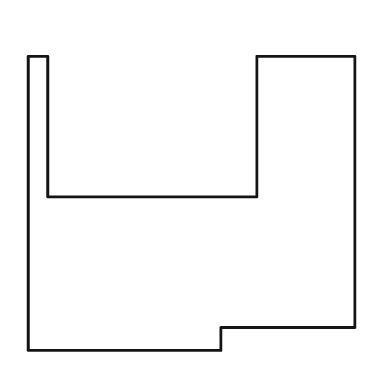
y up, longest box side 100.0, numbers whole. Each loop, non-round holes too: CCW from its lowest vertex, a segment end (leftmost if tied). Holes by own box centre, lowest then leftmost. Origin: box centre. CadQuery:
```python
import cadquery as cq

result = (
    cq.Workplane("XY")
    .moveTo(-50.0, -45.0)
    .lineTo(9.0, -45.0)
    .lineTo(9.0, -38.0)
    .lineTo(50.0, -38.0)
    .lineTo(50.0, 45.0)
    .lineTo(20.0, 45.0)
    .lineTo(20.0, 2.0)
    .lineTo(-44.0, 2.0)
    .lineTo(-44.0, 45.0)
    .lineTo(-50.0, 45.0)
    .close()
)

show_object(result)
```